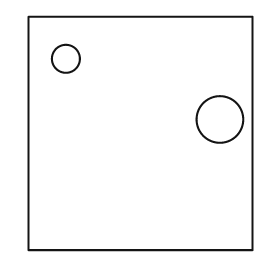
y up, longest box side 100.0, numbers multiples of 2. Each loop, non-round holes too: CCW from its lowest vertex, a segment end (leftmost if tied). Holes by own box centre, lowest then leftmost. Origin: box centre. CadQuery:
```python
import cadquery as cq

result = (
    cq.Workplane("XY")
    .moveTo(-48.0, -50.0)
    .lineTo(48.0, -50.0)
    .lineTo(48.0, 50.0)
    .lineTo(-48.0, 50.0)
    .close()
    .moveTo(34.0, 6.0)
    .circle(10.0)
    .moveTo(-32.0, 32.0)
    .circle(6.0)
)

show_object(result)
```